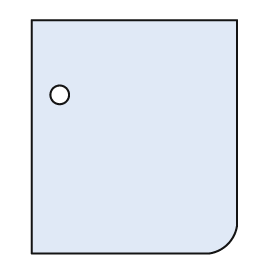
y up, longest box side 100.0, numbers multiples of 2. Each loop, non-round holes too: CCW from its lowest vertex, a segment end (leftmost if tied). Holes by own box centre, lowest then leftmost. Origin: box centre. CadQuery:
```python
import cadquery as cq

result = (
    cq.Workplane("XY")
    .moveTo(-44.0, -50.0)
    .lineTo(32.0, -50.0)
    .threePointArc((40.0, -46.0), (44.0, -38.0))
    .lineTo(44.0, 50.0)
    .lineTo(-44.0, 50.0)
    .close()
    .moveTo(-32.0, 18.0)
    .circle(4.0)
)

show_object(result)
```